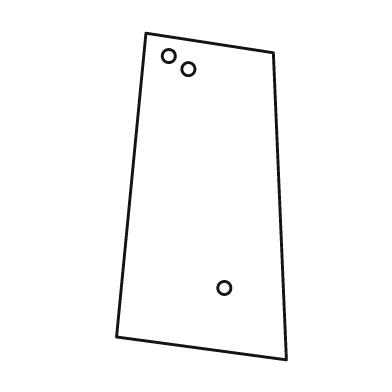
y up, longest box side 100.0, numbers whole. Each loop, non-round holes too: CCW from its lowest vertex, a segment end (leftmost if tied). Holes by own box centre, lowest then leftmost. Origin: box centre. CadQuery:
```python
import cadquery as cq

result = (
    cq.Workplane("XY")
    .moveTo(26.0, -50.0)
    .lineTo(22.0, 44.0)
    .lineTo(-17.0, 50.0)
    .lineTo(-26.0, -43.0)
    .close()
    .moveTo(7.0, -28.0)
    .circle(2.0)
    .moveTo(-4.0, 39.0)
    .circle(2.0)
    .moveTo(-10.0, 43.0)
    .circle(2.0)
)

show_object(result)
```